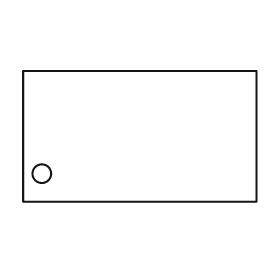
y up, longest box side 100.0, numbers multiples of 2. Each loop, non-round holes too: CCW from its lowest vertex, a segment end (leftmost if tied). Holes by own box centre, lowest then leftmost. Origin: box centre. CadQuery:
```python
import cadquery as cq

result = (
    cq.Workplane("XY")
    .moveTo(-50.0, -28.0)
    .lineTo(50.0, -28.0)
    .lineTo(50.0, 28.0)
    .lineTo(-50.0, 28.0)
    .close()
    .moveTo(-42.0, -16.0)
    .circle(4.0)
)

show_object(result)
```